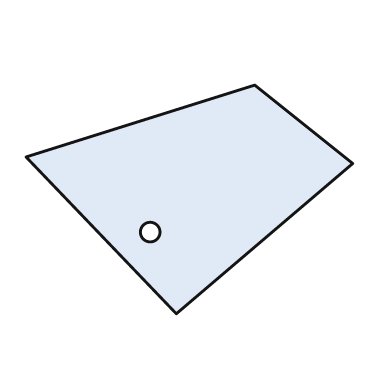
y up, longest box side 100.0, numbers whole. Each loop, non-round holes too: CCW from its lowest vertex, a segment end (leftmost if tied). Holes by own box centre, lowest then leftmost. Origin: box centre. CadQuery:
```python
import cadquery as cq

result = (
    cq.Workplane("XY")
    .moveTo(-4.0, -35.0)
    .lineTo(50.0, 11.0)
    .lineTo(20.0, 35.0)
    .lineTo(-50.0, 13.0)
    .close()
    .moveTo(-12.0, -10.0)
    .circle(3.0)
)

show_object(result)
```